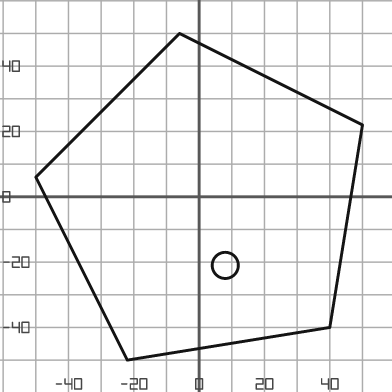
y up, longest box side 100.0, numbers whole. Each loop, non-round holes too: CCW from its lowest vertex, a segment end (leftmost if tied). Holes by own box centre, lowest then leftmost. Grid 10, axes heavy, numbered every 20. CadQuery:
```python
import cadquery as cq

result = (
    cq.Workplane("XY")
    .moveTo(-22.0, -50.0)
    .lineTo(40.0, -40.0)
    .lineTo(50.0, 22.0)
    .lineTo(-6.0, 50.0)
    .lineTo(-50.0, 6.0)
    .close()
    .moveTo(8.0, -21.0)
    .circle(4.0)
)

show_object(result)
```